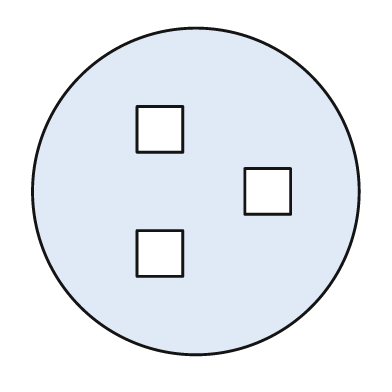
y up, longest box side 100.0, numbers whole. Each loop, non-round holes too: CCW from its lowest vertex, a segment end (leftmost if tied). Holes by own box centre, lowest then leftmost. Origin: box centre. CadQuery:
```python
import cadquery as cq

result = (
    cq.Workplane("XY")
    .moveTo(0.0, 0.0)
    .circle(50.0)
    .moveTo(-18.0, -26.0)
    .lineTo(-4.0, -26.0)
    .lineTo(-4.0, -12.0)
    .lineTo(-18.0, -12.0)
    .close()
    .moveTo(15.0, -7.0)
    .lineTo(29.0, -7.0)
    .lineTo(29.0, 7.0)
    .lineTo(15.0, 7.0)
    .close()
    .moveTo(-18.0, 12.0)
    .lineTo(-4.0, 12.0)
    .lineTo(-4.0, 26.0)
    .lineTo(-18.0, 26.0)
    .close()
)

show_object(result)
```